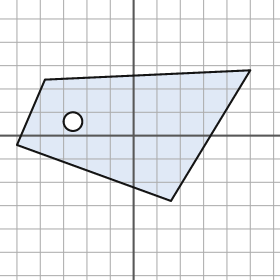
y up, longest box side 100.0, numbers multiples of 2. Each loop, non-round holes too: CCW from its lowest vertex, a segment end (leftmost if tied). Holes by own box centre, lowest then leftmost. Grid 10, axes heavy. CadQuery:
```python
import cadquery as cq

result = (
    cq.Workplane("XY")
    .moveTo(16.0, -28.0)
    .lineTo(50.0, 28.0)
    .lineTo(-38.0, 24.0)
    .lineTo(-50.0, -4.0)
    .close()
    .moveTo(-26.0, 6.0)
    .circle(4.0)
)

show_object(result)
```